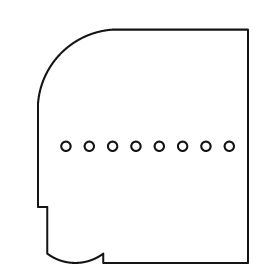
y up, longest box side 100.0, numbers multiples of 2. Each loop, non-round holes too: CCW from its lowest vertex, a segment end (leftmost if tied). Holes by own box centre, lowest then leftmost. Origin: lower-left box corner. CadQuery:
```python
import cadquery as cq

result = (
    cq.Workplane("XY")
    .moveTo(28.0, 0.0)
    .lineTo(90.0, 0.0)
    .lineTo(90.0, 100.0)
    .lineTo(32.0, 100.0)
    .threePointArc((10.0, 90.0), (0.0, 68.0))
    .lineTo(0.0, 24.0)
    .lineTo(4.0, 24.0)
    .lineTo(4.0, 4.0)
    .threePointArc((16.0, 0.0), (28.0, 4.0))
    .close()
    .moveTo(12.0, 50.0)
    .circle(2.0)
    .moveTo(22.0, 50.0)
    .circle(2.0)
    .moveTo(32.0, 50.0)
    .circle(2.0)
    .moveTo(42.0, 50.0)
    .circle(2.0)
    .moveTo(52.0, 50.0)
    .circle(2.0)
    .moveTo(62.0, 50.0)
    .circle(2.0)
    .moveTo(72.0, 50.0)
    .circle(2.0)
    .moveTo(82.0, 50.0)
    .circle(2.0)
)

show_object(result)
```